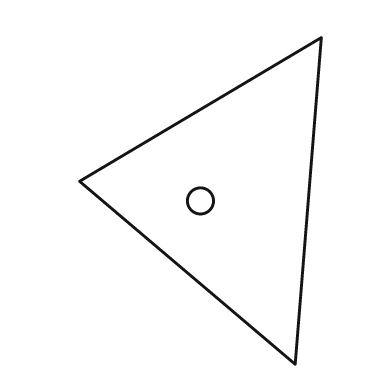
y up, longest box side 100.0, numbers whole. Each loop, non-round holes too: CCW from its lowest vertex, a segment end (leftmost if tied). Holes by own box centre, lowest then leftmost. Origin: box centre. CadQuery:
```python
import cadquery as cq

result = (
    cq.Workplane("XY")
    .moveTo(29.0, -50.0)
    .lineTo(37.0, 50.0)
    .lineTo(-37.0, 6.0)
    .close()
    .moveTo(0.0, 0.0)
    .circle(4.0)
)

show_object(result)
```